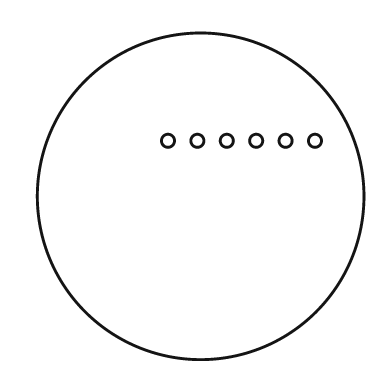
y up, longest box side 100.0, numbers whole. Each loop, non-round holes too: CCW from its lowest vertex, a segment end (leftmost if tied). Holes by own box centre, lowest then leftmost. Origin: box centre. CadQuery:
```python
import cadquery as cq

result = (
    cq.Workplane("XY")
    .moveTo(0.0, 0.0)
    .circle(50.0)
    .moveTo(-10.0, 17.0)
    .circle(2.0)
    .moveTo(-1.0, 17.0)
    .circle(2.0)
    .moveTo(8.0, 17.0)
    .circle(2.0)
    .moveTo(17.0, 17.0)
    .circle(2.0)
    .moveTo(26.0, 17.0)
    .circle(2.0)
    .moveTo(35.0, 17.0)
    .circle(2.0)
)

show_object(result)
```